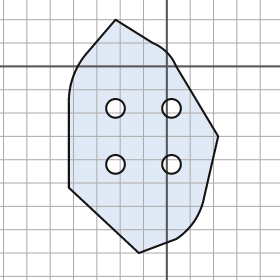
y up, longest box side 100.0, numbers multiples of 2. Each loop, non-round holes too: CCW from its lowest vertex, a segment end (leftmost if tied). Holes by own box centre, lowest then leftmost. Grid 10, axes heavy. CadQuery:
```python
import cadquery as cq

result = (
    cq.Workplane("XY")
    .moveTo(-12.0, -80.0)
    .lineTo(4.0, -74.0)
    .threePointArc((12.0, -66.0), (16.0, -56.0))
    .lineTo(22.0, -30.0)
    .lineTo(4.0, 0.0)
    .threePointArc((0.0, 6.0), (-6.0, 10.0))
    .lineTo(-22.0, 20.0)
    .lineTo(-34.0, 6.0)
    .threePointArc((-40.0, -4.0), (-42.0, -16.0))
    .lineTo(-42.0, -52.0)
    .close()
    .moveTo(-22.0, -42.0)
    .circle(4.0)
    .moveTo(2.0, -42.0)
    .circle(4.0)
    .moveTo(-22.0, -18.0)
    .circle(4.0)
    .moveTo(2.0, -18.0)
    .circle(4.0)
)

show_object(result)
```